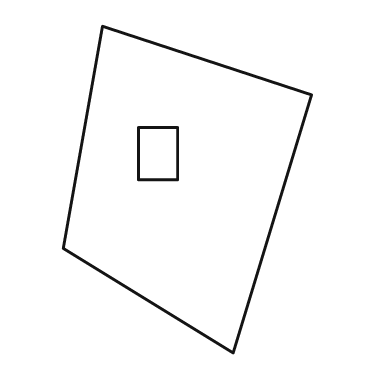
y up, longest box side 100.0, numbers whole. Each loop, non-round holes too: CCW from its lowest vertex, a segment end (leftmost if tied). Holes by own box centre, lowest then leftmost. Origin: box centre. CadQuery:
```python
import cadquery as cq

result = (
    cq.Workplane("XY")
    .moveTo(14.0, -50.0)
    .lineTo(38.0, 29.0)
    .lineTo(-26.0, 50.0)
    .lineTo(-38.0, -18.0)
    .close()
    .moveTo(-15.0, 3.0)
    .lineTo(-3.0, 3.0)
    .lineTo(-3.0, 19.0)
    .lineTo(-15.0, 19.0)
    .close()
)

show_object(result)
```